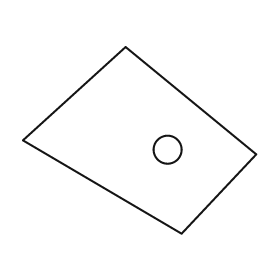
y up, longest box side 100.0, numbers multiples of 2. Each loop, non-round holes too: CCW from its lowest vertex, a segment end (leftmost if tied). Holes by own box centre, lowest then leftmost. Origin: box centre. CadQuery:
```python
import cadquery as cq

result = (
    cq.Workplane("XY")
    .moveTo(18.0, -40.0)
    .lineTo(50.0, -6.0)
    .lineTo(-6.0, 40.0)
    .lineTo(-50.0, 0.0)
    .close()
    .moveTo(12.0, -4.0)
    .circle(6.0)
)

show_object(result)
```